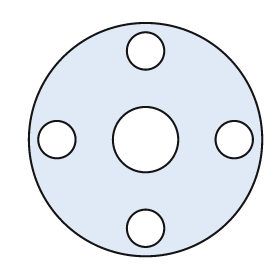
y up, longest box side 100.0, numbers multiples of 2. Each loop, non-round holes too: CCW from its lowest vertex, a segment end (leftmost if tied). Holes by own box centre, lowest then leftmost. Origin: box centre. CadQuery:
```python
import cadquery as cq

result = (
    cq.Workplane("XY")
    .moveTo(0.0, 0.0)
    .circle(50.0)
    .moveTo(0.0, -38.0)
    .circle(8.0)
    .moveTo(-38.0, 0.0)
    .circle(8.0)
    .moveTo(0.0, 0.0)
    .circle(14.0)
    .moveTo(38.0, 0.0)
    .circle(8.0)
    .moveTo(0.0, 38.0)
    .circle(8.0)
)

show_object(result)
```